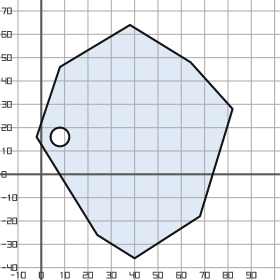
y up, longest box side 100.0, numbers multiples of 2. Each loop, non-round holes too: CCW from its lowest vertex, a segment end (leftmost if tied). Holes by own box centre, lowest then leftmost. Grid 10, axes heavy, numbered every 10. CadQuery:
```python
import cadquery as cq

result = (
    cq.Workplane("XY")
    .moveTo(40.0, -36.0)
    .lineTo(68.0, -18.0)
    .lineTo(82.0, 28.0)
    .lineTo(64.0, 48.0)
    .lineTo(38.0, 64.0)
    .lineTo(8.0, 46.0)
    .lineTo(-2.0, 16.0)
    .lineTo(24.0, -26.0)
    .close()
    .moveTo(8.0, 16.0)
    .circle(4.0)
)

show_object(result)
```